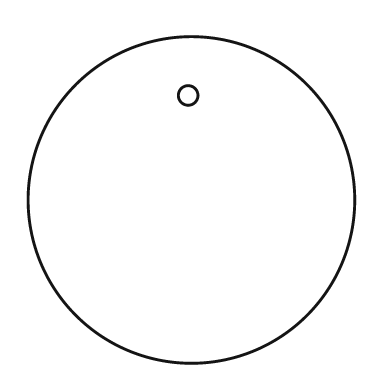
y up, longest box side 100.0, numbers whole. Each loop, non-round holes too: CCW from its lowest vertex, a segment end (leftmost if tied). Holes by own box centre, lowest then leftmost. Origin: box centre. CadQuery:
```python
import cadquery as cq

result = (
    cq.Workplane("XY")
    .moveTo(0.0, 0.0)
    .circle(50.0)
    .moveTo(-1.0, 32.0)
    .circle(3.0)
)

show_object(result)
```